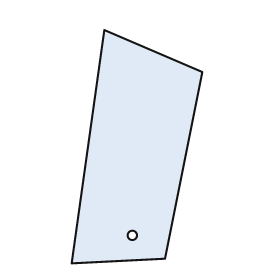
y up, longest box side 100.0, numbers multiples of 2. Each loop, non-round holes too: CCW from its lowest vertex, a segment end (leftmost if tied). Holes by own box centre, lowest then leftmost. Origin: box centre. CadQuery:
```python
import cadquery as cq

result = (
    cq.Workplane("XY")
    .moveTo(-28.0, -50.0)
    .lineTo(12.0, -48.0)
    .lineTo(28.0, 32.0)
    .lineTo(-14.0, 50.0)
    .close()
    .moveTo(-2.0, -38.0)
    .circle(2.0)
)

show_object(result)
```